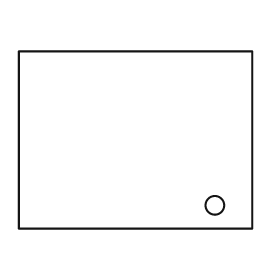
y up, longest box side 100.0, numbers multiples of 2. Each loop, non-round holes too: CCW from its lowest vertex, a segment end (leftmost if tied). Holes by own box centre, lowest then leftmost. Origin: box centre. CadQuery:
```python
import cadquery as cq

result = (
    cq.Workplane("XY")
    .moveTo(-50.0, -38.0)
    .lineTo(50.0, -38.0)
    .lineTo(50.0, 38.0)
    .lineTo(-50.0, 38.0)
    .close()
    .moveTo(34.0, -28.0)
    .circle(4.0)
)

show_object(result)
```